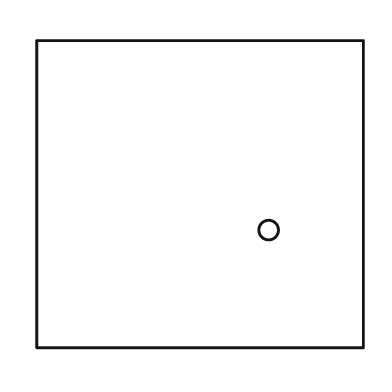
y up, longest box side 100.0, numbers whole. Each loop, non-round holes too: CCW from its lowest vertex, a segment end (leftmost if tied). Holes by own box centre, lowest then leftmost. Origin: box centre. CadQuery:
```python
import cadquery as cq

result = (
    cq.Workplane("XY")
    .moveTo(-50.0, -47.0)
    .lineTo(50.0, -47.0)
    .lineTo(50.0, 47.0)
    .lineTo(-50.0, 47.0)
    .close()
    .moveTo(21.0, -11.0)
    .circle(3.0)
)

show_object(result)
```